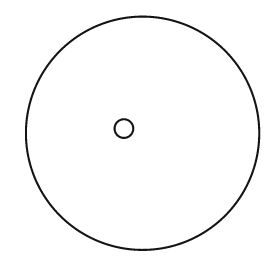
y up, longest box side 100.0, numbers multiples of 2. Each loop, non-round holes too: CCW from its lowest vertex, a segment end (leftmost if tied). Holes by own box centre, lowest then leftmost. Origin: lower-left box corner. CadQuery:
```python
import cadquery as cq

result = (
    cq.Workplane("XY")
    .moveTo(50.0, 50.0)
    .circle(50.0)
    .moveTo(42.0, 52.0)
    .circle(4.0)
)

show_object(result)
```